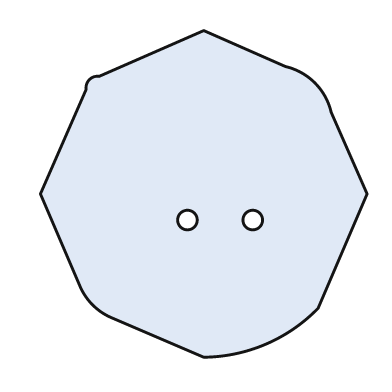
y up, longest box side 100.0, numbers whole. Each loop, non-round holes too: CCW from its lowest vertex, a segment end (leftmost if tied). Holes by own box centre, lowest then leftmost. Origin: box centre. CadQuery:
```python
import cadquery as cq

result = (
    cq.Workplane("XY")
    .moveTo(0.0, -50.0)
    .threePointArc((19.0, -46.0), (35.0, -35.0))
    .lineTo(50.0, 0.0)
    .lineTo(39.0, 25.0)
    .threePointArc((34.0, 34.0), (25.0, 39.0))
    .lineTo(0.0, 50.0)
    .lineTo(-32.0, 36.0)
    .threePointArc((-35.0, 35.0), (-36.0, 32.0))
    .lineTo(-50.0, 0.0)
    .lineTo(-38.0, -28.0)
    .threePointArc((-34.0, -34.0), (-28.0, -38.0))
    .close()
    .moveTo(-5.0, -8.0)
    .circle(3.0)
    .moveTo(15.0, -8.0)
    .circle(3.0)
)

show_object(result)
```